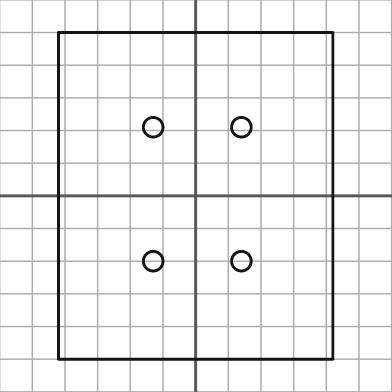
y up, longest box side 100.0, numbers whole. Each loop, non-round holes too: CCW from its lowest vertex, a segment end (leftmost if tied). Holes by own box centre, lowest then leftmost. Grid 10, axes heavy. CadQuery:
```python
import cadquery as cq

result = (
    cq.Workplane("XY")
    .moveTo(-42.0, -50.0)
    .lineTo(42.0, -50.0)
    .lineTo(42.0, 50.0)
    .lineTo(-42.0, 50.0)
    .close()
    .moveTo(-13.0, -20.0)
    .circle(3.0)
    .moveTo(14.0, -20.0)
    .circle(3.0)
    .moveTo(-13.0, 21.0)
    .circle(3.0)
    .moveTo(14.0, 21.0)
    .circle(3.0)
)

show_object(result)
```